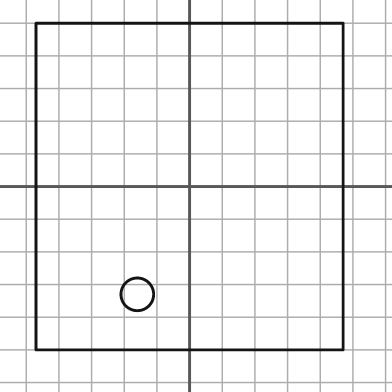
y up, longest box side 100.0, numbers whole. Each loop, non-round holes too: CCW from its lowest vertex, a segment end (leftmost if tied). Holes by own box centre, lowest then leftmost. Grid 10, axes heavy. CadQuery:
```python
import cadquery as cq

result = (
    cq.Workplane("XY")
    .moveTo(-47.0, -50.0)
    .lineTo(47.0, -50.0)
    .lineTo(47.0, 50.0)
    .lineTo(-47.0, 50.0)
    .close()
    .moveTo(-16.0, -33.0)
    .circle(5.0)
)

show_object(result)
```